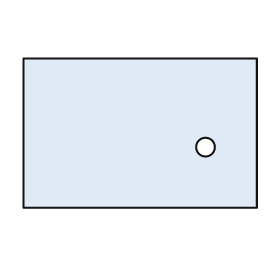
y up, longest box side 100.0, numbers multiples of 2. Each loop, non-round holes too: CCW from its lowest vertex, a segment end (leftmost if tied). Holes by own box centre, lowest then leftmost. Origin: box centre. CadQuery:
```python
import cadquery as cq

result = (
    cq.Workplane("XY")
    .moveTo(-50.0, -32.0)
    .lineTo(50.0, -32.0)
    .lineTo(50.0, 32.0)
    .lineTo(-50.0, 32.0)
    .close()
    .moveTo(28.0, -6.0)
    .circle(4.0)
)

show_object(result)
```